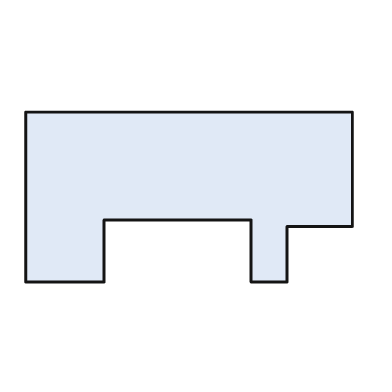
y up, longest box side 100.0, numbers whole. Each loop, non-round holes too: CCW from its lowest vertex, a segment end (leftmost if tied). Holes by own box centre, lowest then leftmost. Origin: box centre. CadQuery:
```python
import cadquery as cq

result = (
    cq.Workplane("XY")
    .moveTo(-50.0, -26.0)
    .lineTo(-26.0, -26.0)
    .lineTo(-26.0, -7.0)
    .lineTo(19.0, -7.0)
    .lineTo(19.0, -26.0)
    .lineTo(30.0, -26.0)
    .lineTo(30.0, -9.0)
    .lineTo(50.0, -9.0)
    .lineTo(50.0, 26.0)
    .lineTo(-50.0, 26.0)
    .close()
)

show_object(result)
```